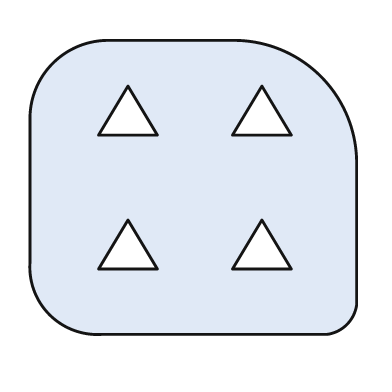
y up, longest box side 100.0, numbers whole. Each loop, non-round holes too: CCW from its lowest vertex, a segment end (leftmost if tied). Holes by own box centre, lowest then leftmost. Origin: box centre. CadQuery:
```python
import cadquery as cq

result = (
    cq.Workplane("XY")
    .moveTo(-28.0, -45.0)
    .lineTo(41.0, -45.0)
    .threePointArc((47.0, -42.0), (50.0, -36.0))
    .lineTo(50.0, 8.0)
    .threePointArc((39.0, 34.0), (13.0, 45.0))
    .lineTo(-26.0, 45.0)
    .threePointArc((-43.0, 38.0), (-50.0, 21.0))
    .lineTo(-50.0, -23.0)
    .threePointArc((-44.0, -39.0), (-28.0, -45.0))
    .close()
    .moveTo(-29.0, -25.0)
    .lineTo(-11.0, -25.0)
    .lineTo(-20.0, -10.0)
    .close()
    .moveTo(12.0, -25.0)
    .lineTo(30.0, -25.0)
    .lineTo(21.0, -10.0)
    .close()
    .moveTo(-29.0, 16.0)
    .lineTo(-11.0, 16.0)
    .lineTo(-20.0, 31.0)
    .close()
    .moveTo(12.0, 16.0)
    .lineTo(30.0, 16.0)
    .lineTo(21.0, 31.0)
    .close()
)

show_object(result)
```